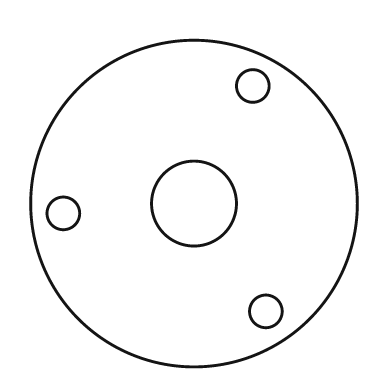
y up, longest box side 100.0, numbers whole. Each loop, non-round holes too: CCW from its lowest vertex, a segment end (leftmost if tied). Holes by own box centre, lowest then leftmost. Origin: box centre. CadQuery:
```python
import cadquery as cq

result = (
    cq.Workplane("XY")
    .moveTo(0.0, 0.0)
    .circle(50.0)
    .moveTo(22.0, -33.0)
    .circle(5.0)
    .moveTo(-40.0, -3.0)
    .circle(5.0)
    .moveTo(0.0, 0.0)
    .circle(13.0)
    .moveTo(18.0, 36.0)
    .circle(5.0)
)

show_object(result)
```